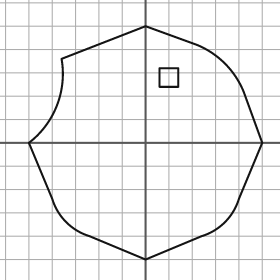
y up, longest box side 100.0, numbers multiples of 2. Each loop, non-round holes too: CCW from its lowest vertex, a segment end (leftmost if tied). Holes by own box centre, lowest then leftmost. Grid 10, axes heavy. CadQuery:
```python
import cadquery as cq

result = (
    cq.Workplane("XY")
    .moveTo(0.0, -50.0)
    .lineTo(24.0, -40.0)
    .threePointArc((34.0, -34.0), (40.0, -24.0))
    .lineTo(50.0, 0.0)
    .lineTo(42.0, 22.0)
    .threePointArc((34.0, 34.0), (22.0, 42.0))
    .lineTo(0.0, 50.0)
    .lineTo(-36.0, 36.0)
    .threePointArc((-38.0, 16.0), (-50.0, 0.0))
    .lineTo(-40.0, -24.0)
    .threePointArc((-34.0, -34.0), (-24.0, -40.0))
    .close()
    .moveTo(6.0, 24.0)
    .lineTo(14.0, 24.0)
    .lineTo(14.0, 32.0)
    .lineTo(6.0, 32.0)
    .close()
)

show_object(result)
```